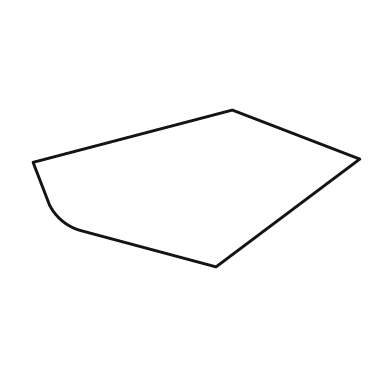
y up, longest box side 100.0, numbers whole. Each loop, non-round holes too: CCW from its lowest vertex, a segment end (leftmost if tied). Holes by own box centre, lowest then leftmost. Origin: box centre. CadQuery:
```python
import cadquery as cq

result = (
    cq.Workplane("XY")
    .moveTo(6.0, -24.0)
    .lineTo(50.0, 9.0)
    .lineTo(11.0, 24.0)
    .lineTo(-50.0, 8.0)
    .lineTo(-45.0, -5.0)
    .threePointArc((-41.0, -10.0), (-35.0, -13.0))
    .close()
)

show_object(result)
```